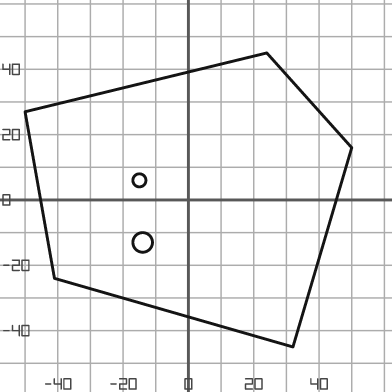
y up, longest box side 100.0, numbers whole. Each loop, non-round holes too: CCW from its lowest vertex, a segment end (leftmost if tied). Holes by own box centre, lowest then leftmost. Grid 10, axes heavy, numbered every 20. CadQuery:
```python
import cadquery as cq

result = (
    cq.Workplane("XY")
    .moveTo(32.0, -45.0)
    .lineTo(50.0, 16.0)
    .lineTo(24.0, 45.0)
    .lineTo(-50.0, 27.0)
    .lineTo(-41.0, -24.0)
    .close()
    .moveTo(-14.0, -13.0)
    .circle(3.0)
    .moveTo(-15.0, 6.0)
    .circle(2.0)
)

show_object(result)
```